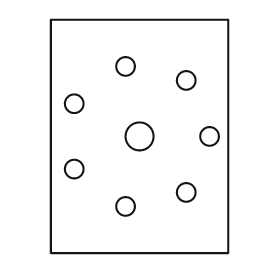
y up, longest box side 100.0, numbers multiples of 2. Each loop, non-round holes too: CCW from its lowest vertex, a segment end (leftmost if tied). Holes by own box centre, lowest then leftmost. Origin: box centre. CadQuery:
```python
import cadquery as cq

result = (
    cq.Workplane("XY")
    .moveTo(-38.0, -50.0)
    .lineTo(38.0, -50.0)
    .lineTo(38.0, 50.0)
    .lineTo(-38.0, 50.0)
    .close()
    .moveTo(-6.0, -30.0)
    .circle(4.0)
    .moveTo(20.0, -24.0)
    .circle(4.0)
    .moveTo(-28.0, -14.0)
    .circle(4.0)
    .moveTo(0.0, 0.0)
    .circle(6.0)
    .moveTo(30.0, 0.0)
    .circle(4.0)
    .moveTo(-28.0, 14.0)
    .circle(4.0)
    .moveTo(20.0, 24.0)
    .circle(4.0)
    .moveTo(-6.0, 30.0)
    .circle(4.0)
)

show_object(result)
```